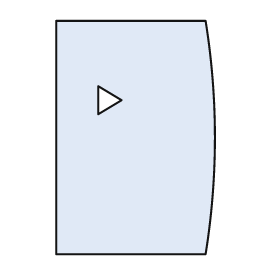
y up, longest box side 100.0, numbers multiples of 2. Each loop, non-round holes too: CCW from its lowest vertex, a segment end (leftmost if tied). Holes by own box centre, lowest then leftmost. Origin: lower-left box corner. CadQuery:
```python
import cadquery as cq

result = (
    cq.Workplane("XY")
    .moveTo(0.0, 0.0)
    .lineTo(64.0, 0.0)
    .threePointArc((68.0, 50.0), (64.0, 100.0))
    .lineTo(0.0, 100.0)
    .close()
    .moveTo(18.0, 60.0)
    .lineTo(28.0, 66.0)
    .lineTo(18.0, 72.0)
    .close()
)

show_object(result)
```